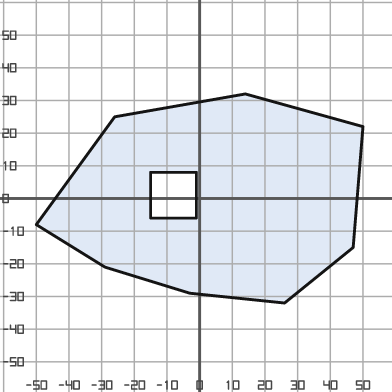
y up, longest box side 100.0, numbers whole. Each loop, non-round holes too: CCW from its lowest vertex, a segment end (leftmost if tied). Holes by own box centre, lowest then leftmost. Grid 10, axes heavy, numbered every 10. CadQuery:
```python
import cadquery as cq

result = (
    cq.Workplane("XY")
    .moveTo(26.0, -32.0)
    .lineTo(47.0, -15.0)
    .lineTo(50.0, 22.0)
    .lineTo(14.0, 32.0)
    .lineTo(-26.0, 25.0)
    .lineTo(-50.0, -8.0)
    .lineTo(-29.0, -21.0)
    .lineTo(-3.0, -29.0)
    .close()
    .moveTo(-15.0, -6.0)
    .lineTo(-1.0, -6.0)
    .lineTo(-1.0, 8.0)
    .lineTo(-15.0, 8.0)
    .close()
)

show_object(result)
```